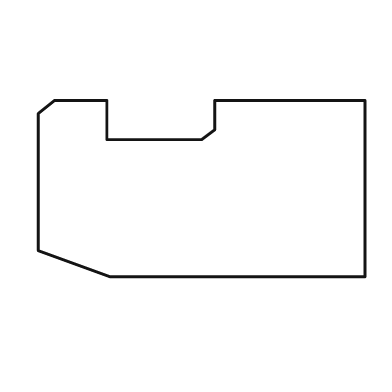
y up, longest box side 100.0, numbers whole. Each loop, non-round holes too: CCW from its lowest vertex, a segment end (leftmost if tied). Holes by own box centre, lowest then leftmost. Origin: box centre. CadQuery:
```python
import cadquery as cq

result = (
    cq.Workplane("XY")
    .moveTo(-28.0, -27.0)
    .lineTo(50.0, -27.0)
    .lineTo(50.0, 27.0)
    .lineTo(4.0, 27.0)
    .lineTo(4.0, 18.0)
    .lineTo(0.0, 15.0)
    .lineTo(-29.0, 15.0)
    .lineTo(-29.0, 27.0)
    .lineTo(-45.0, 27.0)
    .lineTo(-50.0, 23.0)
    .lineTo(-50.0, -19.0)
    .close()
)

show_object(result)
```